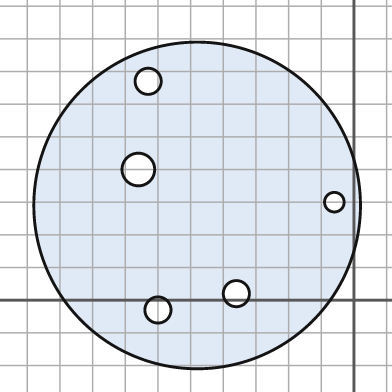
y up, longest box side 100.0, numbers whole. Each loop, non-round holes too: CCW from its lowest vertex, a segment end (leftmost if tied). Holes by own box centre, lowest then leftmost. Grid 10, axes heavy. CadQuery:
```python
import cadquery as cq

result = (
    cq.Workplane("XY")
    .moveTo(-48.0, 29.0)
    .circle(50.0)
    .moveTo(-60.0, -3.0)
    .circle(4.0)
    .moveTo(-36.0, 2.0)
    .circle(4.0)
    .moveTo(-6.0, 30.0)
    .circle(3.0)
    .moveTo(-66.0, 40.0)
    .circle(5.0)
    .moveTo(-63.0, 67.0)
    .circle(4.0)
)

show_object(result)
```